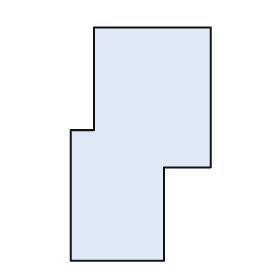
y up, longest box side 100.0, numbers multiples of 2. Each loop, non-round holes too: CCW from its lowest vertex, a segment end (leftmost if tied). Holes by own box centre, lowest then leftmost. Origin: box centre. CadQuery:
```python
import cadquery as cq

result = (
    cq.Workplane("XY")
    .moveTo(-30.0, -50.0)
    .lineTo(10.0, -50.0)
    .lineTo(10.0, -10.0)
    .lineTo(30.0, -10.0)
    .lineTo(30.0, 50.0)
    .lineTo(-20.0, 50.0)
    .lineTo(-20.0, 6.0)
    .lineTo(-30.0, 6.0)
    .close()
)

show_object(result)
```